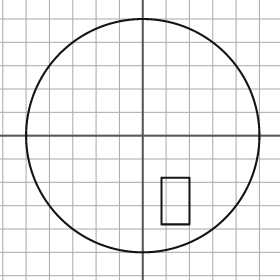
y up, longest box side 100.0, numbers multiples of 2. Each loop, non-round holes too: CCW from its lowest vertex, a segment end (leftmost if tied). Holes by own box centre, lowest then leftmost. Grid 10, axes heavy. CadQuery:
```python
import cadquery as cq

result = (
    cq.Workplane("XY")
    .moveTo(0.0, 0.0)
    .circle(50.0)
    .moveTo(8.0, -38.0)
    .lineTo(20.0, -38.0)
    .lineTo(20.0, -18.0)
    .lineTo(8.0, -18.0)
    .close()
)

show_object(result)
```